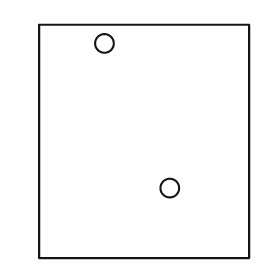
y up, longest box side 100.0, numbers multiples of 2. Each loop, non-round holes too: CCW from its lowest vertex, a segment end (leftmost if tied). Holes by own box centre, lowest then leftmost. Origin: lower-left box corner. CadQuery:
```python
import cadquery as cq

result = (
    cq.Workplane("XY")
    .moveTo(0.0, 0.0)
    .lineTo(90.0, 0.0)
    .lineTo(90.0, 100.0)
    .lineTo(0.0, 100.0)
    .close()
    .moveTo(56.0, 30.0)
    .circle(4.0)
    .moveTo(28.0, 92.0)
    .circle(4.0)
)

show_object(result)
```